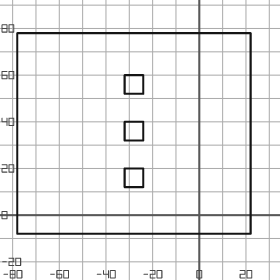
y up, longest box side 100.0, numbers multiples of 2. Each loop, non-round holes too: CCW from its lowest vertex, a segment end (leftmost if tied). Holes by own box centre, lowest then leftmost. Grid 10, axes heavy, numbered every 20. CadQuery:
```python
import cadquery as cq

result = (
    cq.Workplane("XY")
    .moveTo(-78.0, -8.0)
    .lineTo(22.0, -8.0)
    .lineTo(22.0, 78.0)
    .lineTo(-78.0, 78.0)
    .close()
    .moveTo(-32.0, 12.0)
    .lineTo(-24.0, 12.0)
    .lineTo(-24.0, 20.0)
    .lineTo(-32.0, 20.0)
    .close()
    .moveTo(-32.0, 32.0)
    .lineTo(-24.0, 32.0)
    .lineTo(-24.0, 40.0)
    .lineTo(-32.0, 40.0)
    .close()
    .moveTo(-32.0, 52.0)
    .lineTo(-24.0, 52.0)
    .lineTo(-24.0, 60.0)
    .lineTo(-32.0, 60.0)
    .close()
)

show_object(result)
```